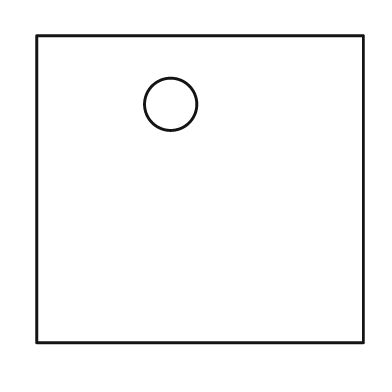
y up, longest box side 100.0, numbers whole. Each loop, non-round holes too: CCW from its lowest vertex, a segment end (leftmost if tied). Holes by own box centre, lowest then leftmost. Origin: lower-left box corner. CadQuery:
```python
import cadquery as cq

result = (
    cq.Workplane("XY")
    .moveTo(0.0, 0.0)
    .lineTo(100.0, 0.0)
    .lineTo(100.0, 94.0)
    .lineTo(0.0, 94.0)
    .close()
    .moveTo(41.0, 73.0)
    .circle(8.0)
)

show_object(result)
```